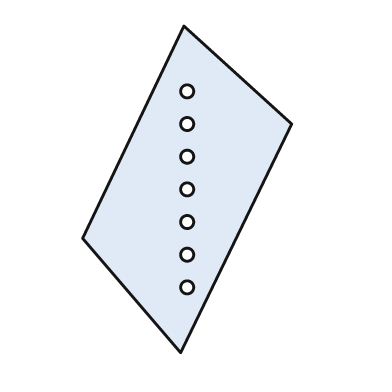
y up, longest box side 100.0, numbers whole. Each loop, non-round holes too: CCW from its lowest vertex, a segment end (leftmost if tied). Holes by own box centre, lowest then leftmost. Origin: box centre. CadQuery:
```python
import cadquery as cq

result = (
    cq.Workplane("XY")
    .moveTo(-2.0, -50.0)
    .lineTo(32.0, 20.0)
    .lineTo(-1.0, 50.0)
    .lineTo(-32.0, -15.0)
    .close()
    .moveTo(0.0, -30.0)
    .circle(2.0)
    .moveTo(0.0, -20.0)
    .circle(2.0)
    .moveTo(0.0, -10.0)
    .circle(2.0)
    .moveTo(0.0, 0.0)
    .circle(2.0)
    .moveTo(0.0, 10.0)
    .circle(2.0)
    .moveTo(0.0, 20.0)
    .circle(2.0)
    .moveTo(0.0, 30.0)
    .circle(2.0)
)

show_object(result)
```